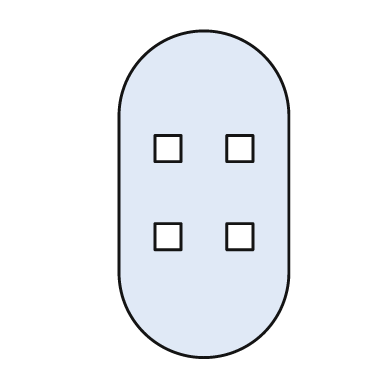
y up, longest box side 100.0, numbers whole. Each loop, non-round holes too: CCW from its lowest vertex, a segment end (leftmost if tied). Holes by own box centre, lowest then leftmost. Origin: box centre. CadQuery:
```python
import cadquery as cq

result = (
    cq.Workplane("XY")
    .moveTo(-26.0, -24.0)
    .threePointArc((0.0, -50.0), (26.0, -24.0))
    .lineTo(26.0, 24.0)
    .threePointArc((0.0, 50.0), (-26.0, 24.0))
    .close()
    .moveTo(-15.0, -17.0)
    .lineTo(-7.0, -17.0)
    .lineTo(-7.0, -9.0)
    .lineTo(-15.0, -9.0)
    .close()
    .moveTo(7.0, -17.0)
    .lineTo(15.0, -17.0)
    .lineTo(15.0, -9.0)
    .lineTo(7.0, -9.0)
    .close()
    .moveTo(-15.0, 10.0)
    .lineTo(-7.0, 10.0)
    .lineTo(-7.0, 18.0)
    .lineTo(-15.0, 18.0)
    .close()
    .moveTo(7.0, 10.0)
    .lineTo(15.0, 10.0)
    .lineTo(15.0, 18.0)
    .lineTo(7.0, 18.0)
    .close()
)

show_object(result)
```